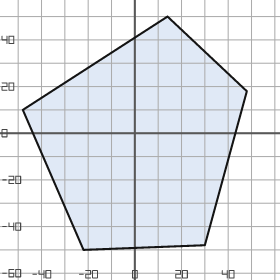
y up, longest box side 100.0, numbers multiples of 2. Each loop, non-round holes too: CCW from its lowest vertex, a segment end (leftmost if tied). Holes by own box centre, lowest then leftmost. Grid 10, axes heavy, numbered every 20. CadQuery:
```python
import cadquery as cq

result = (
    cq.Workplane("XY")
    .moveTo(-22.0, -50.0)
    .lineTo(30.0, -48.0)
    .lineTo(48.0, 18.0)
    .lineTo(14.0, 50.0)
    .lineTo(-48.0, 10.0)
    .close()
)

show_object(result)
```